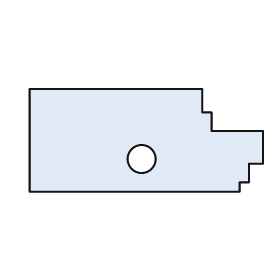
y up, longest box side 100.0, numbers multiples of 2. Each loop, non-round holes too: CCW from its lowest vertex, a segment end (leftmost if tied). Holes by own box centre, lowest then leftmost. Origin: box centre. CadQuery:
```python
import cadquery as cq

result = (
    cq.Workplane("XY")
    .moveTo(-50.0, -22.0)
    .lineTo(40.0, -22.0)
    .lineTo(40.0, -18.0)
    .lineTo(44.0, -18.0)
    .lineTo(44.0, -10.0)
    .lineTo(50.0, -10.0)
    .lineTo(50.0, 4.0)
    .lineTo(28.0, 4.0)
    .lineTo(28.0, 12.0)
    .lineTo(24.0, 12.0)
    .lineTo(24.0, 22.0)
    .lineTo(-50.0, 22.0)
    .close()
    .moveTo(-2.0, -8.0)
    .circle(6.0)
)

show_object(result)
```